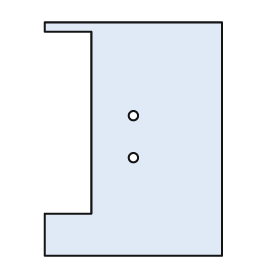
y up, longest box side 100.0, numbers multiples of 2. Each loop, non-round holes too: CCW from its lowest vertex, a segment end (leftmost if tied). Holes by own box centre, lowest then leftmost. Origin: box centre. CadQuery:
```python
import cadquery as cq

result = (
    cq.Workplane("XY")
    .moveTo(-38.0, -50.0)
    .lineTo(38.0, -50.0)
    .lineTo(38.0, 50.0)
    .lineTo(-38.0, 50.0)
    .lineTo(-38.0, 46.0)
    .lineTo(-18.0, 46.0)
    .lineTo(-18.0, -32.0)
    .lineTo(-38.0, -32.0)
    .close()
    .moveTo(0.0, -8.0)
    .circle(2.0)
    .moveTo(0.0, 10.0)
    .circle(2.0)
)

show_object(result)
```